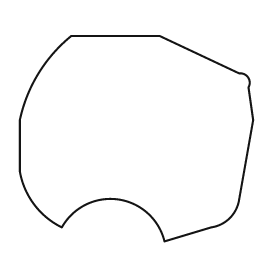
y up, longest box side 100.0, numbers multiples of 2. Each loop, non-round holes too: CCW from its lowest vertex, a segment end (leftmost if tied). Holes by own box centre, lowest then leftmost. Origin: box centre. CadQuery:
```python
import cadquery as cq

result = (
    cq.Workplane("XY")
    .moveTo(12.0, -44.0)
    .lineTo(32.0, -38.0)
    .threePointArc((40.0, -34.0), (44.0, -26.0))
    .lineTo(50.0, 8.0)
    .lineTo(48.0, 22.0)
    .threePointArc((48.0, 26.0), (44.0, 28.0))
    .lineTo(10.0, 44.0)
    .lineTo(-28.0, 44.0)
    .threePointArc((-42.0, 28.0), (-50.0, 8.0))
    .lineTo(-50.0, -14.0)
    .threePointArc((-44.0, -28.0), (-32.0, -38.0))
    .threePointArc((-8.0, -26.0), (12.0, -44.0))
    .close()
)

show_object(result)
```